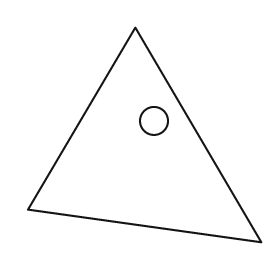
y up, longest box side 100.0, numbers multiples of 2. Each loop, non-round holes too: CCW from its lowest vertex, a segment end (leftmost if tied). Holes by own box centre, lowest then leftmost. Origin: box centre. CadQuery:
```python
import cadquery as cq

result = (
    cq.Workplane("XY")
    .moveTo(50.0, -46.0)
    .lineTo(-4.0, 46.0)
    .lineTo(-50.0, -32.0)
    .close()
    .moveTo(4.0, 6.0)
    .circle(6.0)
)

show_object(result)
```